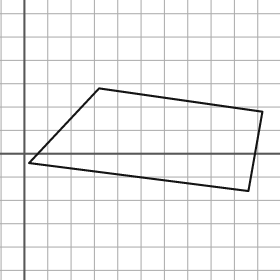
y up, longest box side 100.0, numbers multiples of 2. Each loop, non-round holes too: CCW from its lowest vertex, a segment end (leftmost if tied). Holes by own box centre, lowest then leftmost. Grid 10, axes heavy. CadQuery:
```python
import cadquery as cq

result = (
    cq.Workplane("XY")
    .moveTo(96.0, -16.0)
    .lineTo(102.0, 18.0)
    .lineTo(32.0, 28.0)
    .lineTo(2.0, -4.0)
    .close()
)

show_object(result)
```